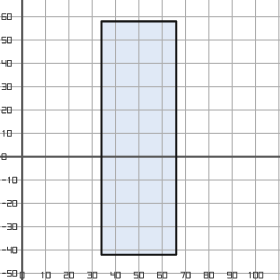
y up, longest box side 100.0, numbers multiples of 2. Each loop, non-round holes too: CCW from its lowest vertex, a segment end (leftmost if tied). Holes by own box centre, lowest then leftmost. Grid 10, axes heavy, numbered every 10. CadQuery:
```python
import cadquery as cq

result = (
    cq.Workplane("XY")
    .moveTo(34.0, -42.0)
    .lineTo(66.0, -42.0)
    .lineTo(66.0, 58.0)
    .lineTo(34.0, 58.0)
    .close()
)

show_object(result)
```